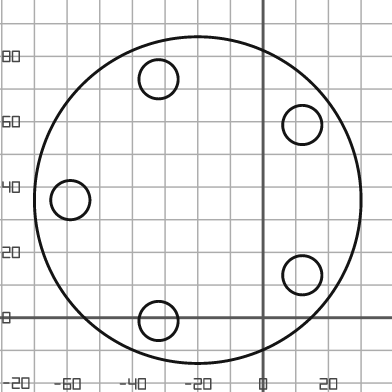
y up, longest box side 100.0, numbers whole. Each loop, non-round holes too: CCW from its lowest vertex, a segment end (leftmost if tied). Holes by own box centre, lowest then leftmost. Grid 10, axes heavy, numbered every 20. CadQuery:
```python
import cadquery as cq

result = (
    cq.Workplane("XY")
    .moveTo(-20.0, 36.0)
    .circle(50.0)
    .moveTo(-32.0, -1.0)
    .circle(6.0)
    .moveTo(12.0, 13.0)
    .circle(6.0)
    .moveTo(-59.0, 36.0)
    .circle(6.0)
    .moveTo(12.0, 59.0)
    .circle(6.0)
    .moveTo(-32.0, 73.0)
    .circle(6.0)
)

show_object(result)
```